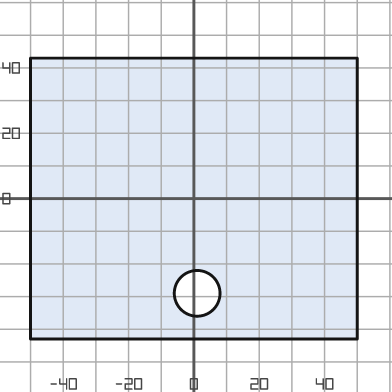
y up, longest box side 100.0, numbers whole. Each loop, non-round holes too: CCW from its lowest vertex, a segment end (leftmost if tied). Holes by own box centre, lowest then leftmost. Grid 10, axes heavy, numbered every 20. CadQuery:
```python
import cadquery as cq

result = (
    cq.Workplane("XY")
    .moveTo(-50.0, -43.0)
    .lineTo(50.0, -43.0)
    .lineTo(50.0, 43.0)
    .lineTo(-50.0, 43.0)
    .close()
    .moveTo(1.0, -29.0)
    .circle(7.0)
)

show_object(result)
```